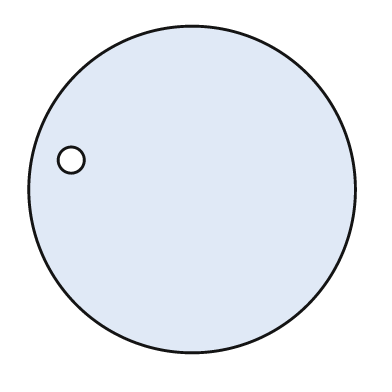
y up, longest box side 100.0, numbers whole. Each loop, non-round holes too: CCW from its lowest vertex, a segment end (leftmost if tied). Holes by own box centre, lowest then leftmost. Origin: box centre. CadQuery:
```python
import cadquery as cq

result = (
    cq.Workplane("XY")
    .moveTo(0.0, 0.0)
    .circle(50.0)
    .moveTo(-37.0, 9.0)
    .circle(4.0)
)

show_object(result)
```